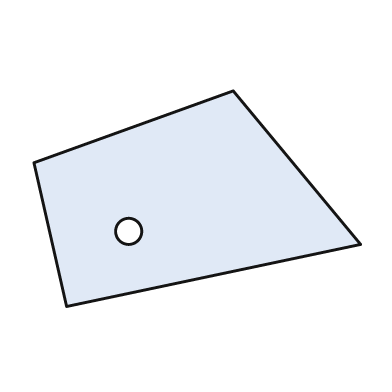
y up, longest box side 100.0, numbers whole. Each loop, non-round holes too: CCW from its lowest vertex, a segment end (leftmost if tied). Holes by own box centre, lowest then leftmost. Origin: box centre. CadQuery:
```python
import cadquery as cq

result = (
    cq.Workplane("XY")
    .moveTo(-40.0, -33.0)
    .lineTo(50.0, -14.0)
    .lineTo(11.0, 33.0)
    .lineTo(-50.0, 11.0)
    .close()
    .moveTo(-21.0, -10.0)
    .circle(4.0)
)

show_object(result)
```